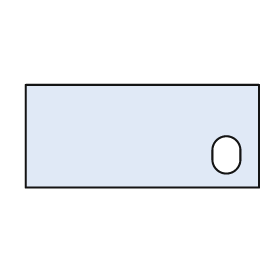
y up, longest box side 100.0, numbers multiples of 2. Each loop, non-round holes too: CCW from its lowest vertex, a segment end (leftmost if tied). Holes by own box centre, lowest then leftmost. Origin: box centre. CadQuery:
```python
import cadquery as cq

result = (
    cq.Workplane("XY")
    .moveTo(-50.0, -22.0)
    .lineTo(50.0, -22.0)
    .lineTo(50.0, 22.0)
    .lineTo(-50.0, 22.0)
    .close()
    .moveTo(30.0, -10.0)
    .threePointArc((36.0, -16.0), (42.0, -10.0))
    .lineTo(42.0, -6.0)
    .threePointArc((36.0, 0.0), (30.0, -6.0))
    .close()
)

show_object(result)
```